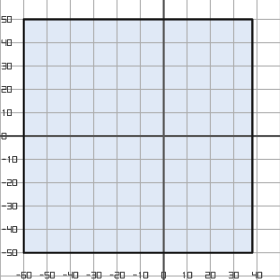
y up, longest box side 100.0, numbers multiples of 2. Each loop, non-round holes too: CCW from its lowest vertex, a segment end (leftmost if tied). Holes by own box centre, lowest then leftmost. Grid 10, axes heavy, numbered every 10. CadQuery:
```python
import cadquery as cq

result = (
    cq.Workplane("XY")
    .moveTo(-60.0, -50.0)
    .lineTo(38.0, -50.0)
    .lineTo(38.0, 50.0)
    .lineTo(-60.0, 50.0)
    .close()
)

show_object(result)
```